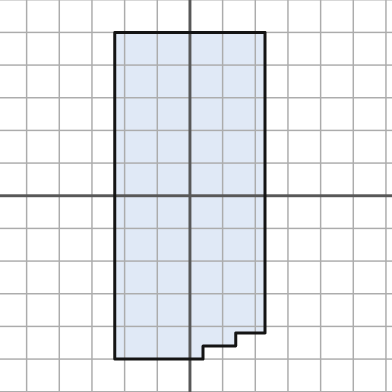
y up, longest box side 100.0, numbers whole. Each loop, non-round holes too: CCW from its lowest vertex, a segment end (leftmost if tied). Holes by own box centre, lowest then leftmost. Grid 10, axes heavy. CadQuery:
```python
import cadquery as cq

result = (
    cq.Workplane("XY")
    .moveTo(-23.0, -50.0)
    .lineTo(4.0, -50.0)
    .lineTo(4.0, -46.0)
    .lineTo(14.0, -46.0)
    .lineTo(14.0, -42.0)
    .lineTo(23.0, -42.0)
    .lineTo(23.0, 50.0)
    .lineTo(-23.0, 50.0)
    .close()
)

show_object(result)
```